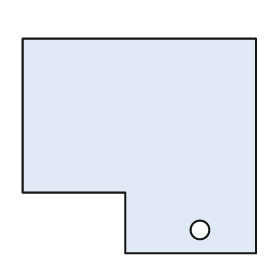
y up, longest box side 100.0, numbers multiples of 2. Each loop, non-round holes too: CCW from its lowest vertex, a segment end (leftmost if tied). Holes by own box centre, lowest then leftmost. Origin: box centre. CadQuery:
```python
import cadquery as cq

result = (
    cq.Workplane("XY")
    .moveTo(-6.0, -46.0)
    .lineTo(50.0, -46.0)
    .lineTo(50.0, 46.0)
    .lineTo(-50.0, 46.0)
    .lineTo(-50.0, -20.0)
    .lineTo(-6.0, -20.0)
    .close()
    .moveTo(26.0, -36.0)
    .circle(4.0)
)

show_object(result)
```